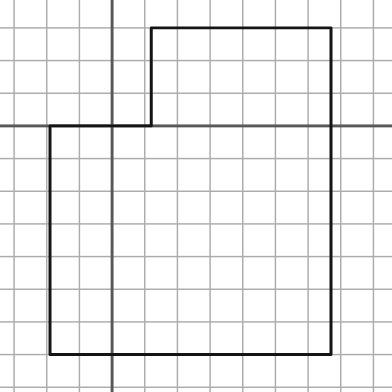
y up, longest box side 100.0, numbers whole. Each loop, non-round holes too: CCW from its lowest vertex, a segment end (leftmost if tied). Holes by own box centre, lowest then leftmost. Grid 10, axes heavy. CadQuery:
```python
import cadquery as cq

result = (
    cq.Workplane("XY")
    .moveTo(-19.0, -70.0)
    .lineTo(67.0, -70.0)
    .lineTo(67.0, 30.0)
    .lineTo(12.0, 30.0)
    .lineTo(12.0, 0.0)
    .lineTo(-19.0, 0.0)
    .close()
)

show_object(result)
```